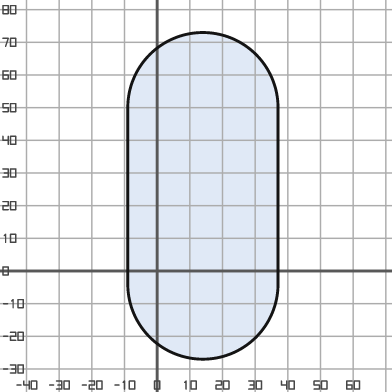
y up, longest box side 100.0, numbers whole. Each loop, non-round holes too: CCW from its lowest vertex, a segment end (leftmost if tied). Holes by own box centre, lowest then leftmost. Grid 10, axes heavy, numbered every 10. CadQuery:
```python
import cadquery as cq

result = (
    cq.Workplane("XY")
    .moveTo(-9.0, -4.0)
    .threePointArc((14.0, -27.0), (37.0, -4.0))
    .lineTo(37.0, 50.0)
    .threePointArc((14.0, 73.0), (-9.0, 50.0))
    .close()
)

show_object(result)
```